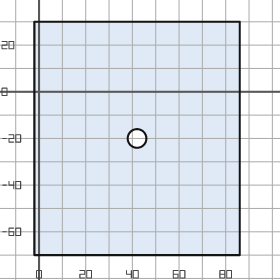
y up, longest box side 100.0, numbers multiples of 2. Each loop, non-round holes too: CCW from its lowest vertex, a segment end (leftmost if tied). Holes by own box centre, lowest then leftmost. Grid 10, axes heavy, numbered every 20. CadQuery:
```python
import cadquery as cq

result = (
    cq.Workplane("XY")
    .moveTo(-2.0, -70.0)
    .lineTo(86.0, -70.0)
    .lineTo(86.0, 30.0)
    .lineTo(-2.0, 30.0)
    .close()
    .moveTo(42.0, -20.0)
    .circle(4.0)
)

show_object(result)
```